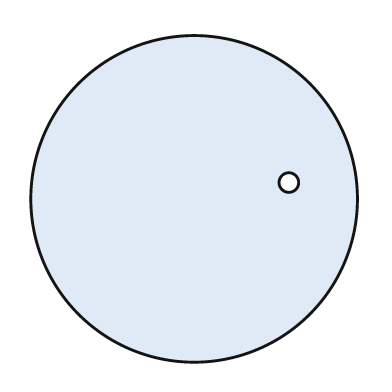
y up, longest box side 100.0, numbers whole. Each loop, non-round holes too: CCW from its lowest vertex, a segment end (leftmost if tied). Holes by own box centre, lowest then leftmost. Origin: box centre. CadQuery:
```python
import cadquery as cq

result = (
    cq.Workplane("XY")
    .moveTo(0.0, 0.0)
    .circle(50.0)
    .moveTo(29.0, 5.0)
    .circle(3.0)
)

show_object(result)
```